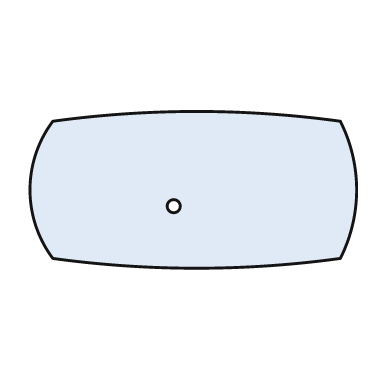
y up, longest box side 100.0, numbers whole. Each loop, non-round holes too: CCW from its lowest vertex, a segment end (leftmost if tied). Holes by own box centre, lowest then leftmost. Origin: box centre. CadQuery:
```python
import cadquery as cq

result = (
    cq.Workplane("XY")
    .moveTo(-43.0, -21.0)
    .threePointArc((1.0, -24.0), (45.0, -21.0))
    .threePointArc((50.0, 0.0), (45.0, 21.0))
    .threePointArc((1.0, 24.0), (-43.0, 21.0))
    .threePointArc((-50.0, 0.0), (-43.0, -21.0))
    .close()
    .moveTo(-6.0, -5.0)
    .circle(2.0)
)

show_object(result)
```